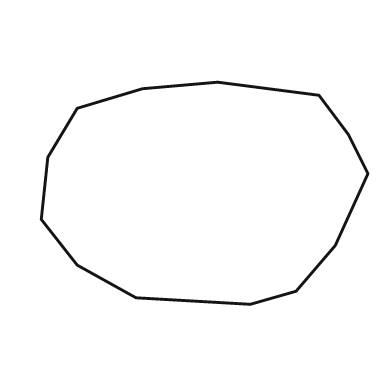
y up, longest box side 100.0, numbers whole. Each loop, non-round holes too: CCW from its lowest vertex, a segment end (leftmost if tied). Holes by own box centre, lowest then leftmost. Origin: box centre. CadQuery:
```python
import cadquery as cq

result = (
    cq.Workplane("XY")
    .moveTo(14.0, -34.0)
    .lineTo(28.0, -30.0)
    .lineTo(40.0, -16.0)
    .lineTo(50.0, 6.0)
    .lineTo(44.0, 18.0)
    .lineTo(35.0, 30.0)
    .lineTo(4.0, 34.0)
    .lineTo(-19.0, 32.0)
    .lineTo(-39.0, 26.0)
    .lineTo(-48.0, 11.0)
    .lineTo(-50.0, -8.0)
    .lineTo(-39.0, -22.0)
    .lineTo(-21.0, -32.0)
    .close()
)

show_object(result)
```